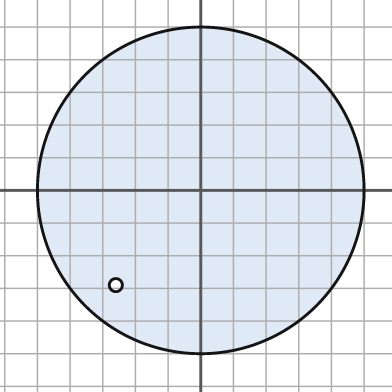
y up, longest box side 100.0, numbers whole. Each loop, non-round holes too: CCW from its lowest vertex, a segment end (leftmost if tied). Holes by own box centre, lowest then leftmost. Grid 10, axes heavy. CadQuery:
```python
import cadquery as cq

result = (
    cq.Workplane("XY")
    .moveTo(0.0, 0.0)
    .circle(50.0)
    .moveTo(-26.0, -29.0)
    .circle(2.0)
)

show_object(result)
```